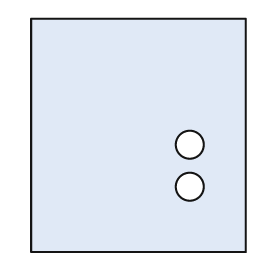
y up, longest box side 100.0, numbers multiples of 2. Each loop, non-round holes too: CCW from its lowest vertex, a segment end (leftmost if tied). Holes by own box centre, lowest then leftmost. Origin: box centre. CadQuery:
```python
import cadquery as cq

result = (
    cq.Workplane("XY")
    .moveTo(-46.0, -50.0)
    .lineTo(46.0, -50.0)
    .lineTo(46.0, 50.0)
    .lineTo(-46.0, 50.0)
    .close()
    .moveTo(22.0, -22.0)
    .circle(6.0)
    .moveTo(22.0, -4.0)
    .circle(6.0)
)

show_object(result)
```